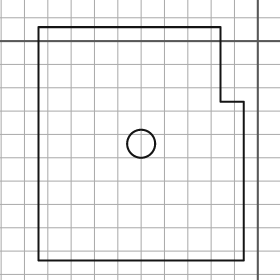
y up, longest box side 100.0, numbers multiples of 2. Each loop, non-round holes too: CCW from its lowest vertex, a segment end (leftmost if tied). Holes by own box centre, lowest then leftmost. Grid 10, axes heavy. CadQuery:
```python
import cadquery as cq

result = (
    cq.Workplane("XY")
    .moveTo(-94.0, -94.0)
    .lineTo(-6.0, -94.0)
    .lineTo(-6.0, -26.0)
    .lineTo(-16.0, -26.0)
    .lineTo(-16.0, 6.0)
    .lineTo(-94.0, 6.0)
    .close()
    .moveTo(-50.0, -44.0)
    .circle(6.0)
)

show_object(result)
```